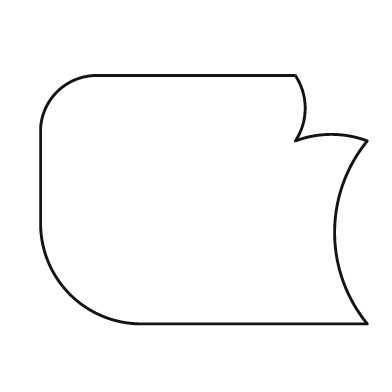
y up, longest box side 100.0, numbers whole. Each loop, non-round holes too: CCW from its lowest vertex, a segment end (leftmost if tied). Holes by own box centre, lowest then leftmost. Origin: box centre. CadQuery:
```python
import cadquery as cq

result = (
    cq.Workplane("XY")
    .moveTo(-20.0, -38.0)
    .lineTo(50.0, -38.0)
    .threePointArc((40.0, -10.0), (50.0, 18.0))
    .threePointArc((39.0, 20.0), (28.0, 18.0))
    .threePointArc((31.0, 28.0), (28.0, 38.0))
    .lineTo(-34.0, 38.0)
    .threePointArc((-45.0, 33.0), (-50.0, 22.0))
    .lineTo(-50.0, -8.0)
    .threePointArc((-41.0, -29.0), (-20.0, -38.0))
    .close()
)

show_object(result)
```